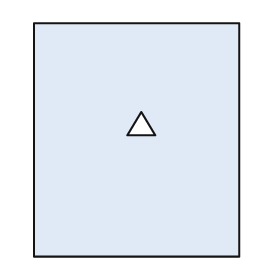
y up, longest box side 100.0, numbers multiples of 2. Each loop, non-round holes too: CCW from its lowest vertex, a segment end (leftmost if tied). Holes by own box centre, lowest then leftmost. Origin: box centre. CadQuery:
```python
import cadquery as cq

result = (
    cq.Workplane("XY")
    .moveTo(-44.0, -50.0)
    .lineTo(44.0, -50.0)
    .lineTo(44.0, 50.0)
    .lineTo(-44.0, 50.0)
    .close()
    .moveTo(-4.0, 2.0)
    .lineTo(8.0, 2.0)
    .lineTo(2.0, 12.0)
    .close()
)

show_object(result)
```